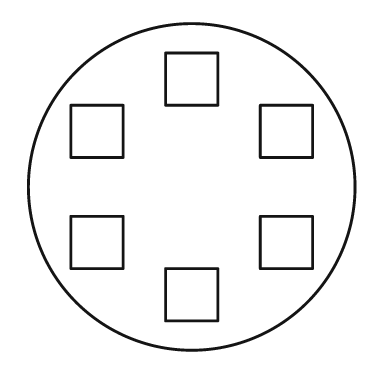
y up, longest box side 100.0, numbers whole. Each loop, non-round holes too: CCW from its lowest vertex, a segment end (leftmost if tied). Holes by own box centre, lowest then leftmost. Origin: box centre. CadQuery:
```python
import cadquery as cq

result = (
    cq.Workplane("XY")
    .moveTo(0.0, 0.0)
    .circle(50.0)
    .moveTo(-8.0, -41.0)
    .lineTo(8.0, -41.0)
    .lineTo(8.0, -25.0)
    .lineTo(-8.0, -25.0)
    .close()
    .moveTo(-37.0, -25.0)
    .lineTo(-21.0, -25.0)
    .lineTo(-21.0, -9.0)
    .lineTo(-37.0, -9.0)
    .close()
    .moveTo(21.0, -25.0)
    .lineTo(37.0, -25.0)
    .lineTo(37.0, -9.0)
    .lineTo(21.0, -9.0)
    .close()
    .moveTo(-37.0, 9.0)
    .lineTo(-21.0, 9.0)
    .lineTo(-21.0, 25.0)
    .lineTo(-37.0, 25.0)
    .close()
    .moveTo(21.0, 9.0)
    .lineTo(37.0, 9.0)
    .lineTo(37.0, 25.0)
    .lineTo(21.0, 25.0)
    .close()
    .moveTo(-8.0, 25.0)
    .lineTo(8.0, 25.0)
    .lineTo(8.0, 41.0)
    .lineTo(-8.0, 41.0)
    .close()
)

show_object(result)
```